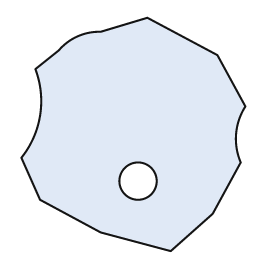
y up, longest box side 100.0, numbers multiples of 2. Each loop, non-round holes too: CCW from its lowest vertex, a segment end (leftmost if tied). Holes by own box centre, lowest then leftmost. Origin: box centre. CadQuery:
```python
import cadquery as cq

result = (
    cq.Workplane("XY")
    .moveTo(16.0, -50.0)
    .lineTo(34.0, -34.0)
    .lineTo(46.0, -12.0)
    .threePointArc((44.0, 0.0), (48.0, 12.0))
    .lineTo(36.0, 34.0)
    .lineTo(6.0, 50.0)
    .lineTo(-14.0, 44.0)
    .threePointArc((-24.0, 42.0), (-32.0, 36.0))
    .lineTo(-42.0, 28.0)
    .threePointArc((-40.0, 8.0), (-48.0, -10.0))
    .lineTo(-40.0, -28.0)
    .lineTo(-14.0, -42.0)
    .close()
    .moveTo(2.0, -20.0)
    .circle(8.0)
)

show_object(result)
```